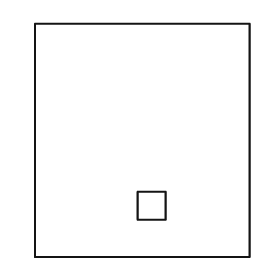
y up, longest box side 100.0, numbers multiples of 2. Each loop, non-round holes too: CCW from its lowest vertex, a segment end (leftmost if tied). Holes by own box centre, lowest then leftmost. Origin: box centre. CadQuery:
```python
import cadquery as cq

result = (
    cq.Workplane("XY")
    .moveTo(-46.0, -50.0)
    .lineTo(46.0, -50.0)
    .lineTo(46.0, 50.0)
    .lineTo(-46.0, 50.0)
    .close()
    .moveTo(-2.0, -34.0)
    .lineTo(10.0, -34.0)
    .lineTo(10.0, -22.0)
    .lineTo(-2.0, -22.0)
    .close()
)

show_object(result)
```